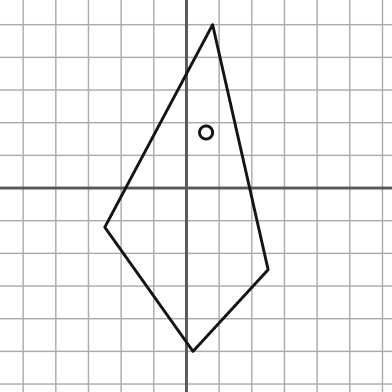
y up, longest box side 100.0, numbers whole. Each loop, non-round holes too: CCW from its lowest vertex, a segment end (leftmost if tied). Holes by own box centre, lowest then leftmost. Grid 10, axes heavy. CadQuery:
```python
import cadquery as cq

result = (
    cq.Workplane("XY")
    .moveTo(2.0, -50.0)
    .lineTo(25.0, -25.0)
    .lineTo(8.0, 50.0)
    .lineTo(-25.0, -12.0)
    .close()
    .moveTo(6.0, 17.0)
    .circle(2.0)
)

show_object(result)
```